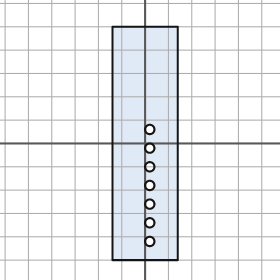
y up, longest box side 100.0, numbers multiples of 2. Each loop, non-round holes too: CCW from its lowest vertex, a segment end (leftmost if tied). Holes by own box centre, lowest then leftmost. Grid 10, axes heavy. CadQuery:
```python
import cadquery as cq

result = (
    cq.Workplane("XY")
    .moveTo(-14.0, -50.0)
    .lineTo(14.0, -50.0)
    .lineTo(14.0, 50.0)
    .lineTo(-14.0, 50.0)
    .close()
    .moveTo(2.0, -42.0)
    .circle(2.0)
    .moveTo(2.0, -34.0)
    .circle(2.0)
    .moveTo(2.0, -26.0)
    .circle(2.0)
    .moveTo(2.0, -18.0)
    .circle(2.0)
    .moveTo(2.0, -10.0)
    .circle(2.0)
    .moveTo(2.0, -2.0)
    .circle(2.0)
    .moveTo(2.0, 6.0)
    .circle(2.0)
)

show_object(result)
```